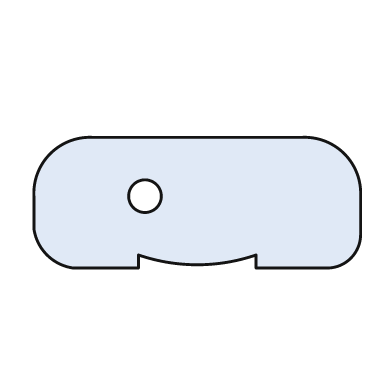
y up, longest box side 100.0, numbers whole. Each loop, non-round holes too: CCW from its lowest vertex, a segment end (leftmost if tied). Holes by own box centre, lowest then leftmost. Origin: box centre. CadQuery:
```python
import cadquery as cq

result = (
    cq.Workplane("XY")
    .moveTo(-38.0, -20.0)
    .lineTo(-18.0, -20.0)
    .lineTo(-18.0, -16.0)
    .threePointArc((0.0, -19.0), (18.0, -16.0))
    .lineTo(18.0, -20.0)
    .lineTo(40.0, -20.0)
    .threePointArc((47.0, -17.0), (50.0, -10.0))
    .lineTo(50.0, 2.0)
    .threePointArc((45.0, 15.0), (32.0, 20.0))
    .lineTo(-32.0, 20.0)
    .threePointArc((-45.0, 15.0), (-50.0, 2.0))
    .lineTo(-50.0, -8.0)
    .threePointArc((-46.0, -16.0), (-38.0, -20.0))
    .close()
    .moveTo(-16.0, 2.0)
    .circle(5.0)
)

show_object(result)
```